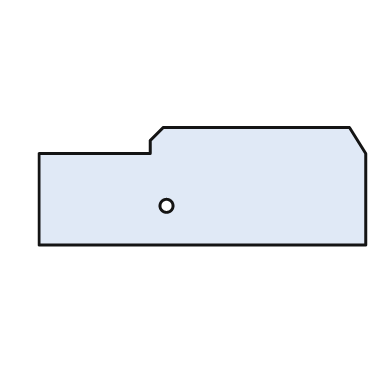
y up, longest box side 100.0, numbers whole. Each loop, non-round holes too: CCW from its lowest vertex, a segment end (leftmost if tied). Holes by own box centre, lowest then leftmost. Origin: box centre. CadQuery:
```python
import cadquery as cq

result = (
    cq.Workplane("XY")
    .moveTo(-50.0, -18.0)
    .lineTo(50.0, -18.0)
    .lineTo(50.0, 10.0)
    .lineTo(45.0, 18.0)
    .lineTo(-12.0, 18.0)
    .lineTo(-16.0, 14.0)
    .lineTo(-16.0, 10.0)
    .lineTo(-50.0, 10.0)
    .close()
    .moveTo(-11.0, -6.0)
    .circle(2.0)
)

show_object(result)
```